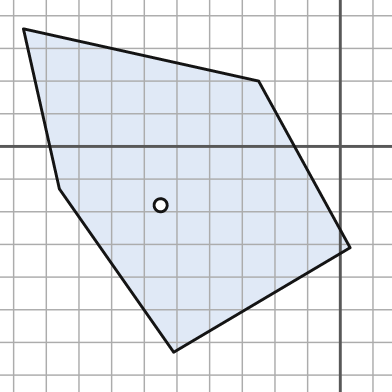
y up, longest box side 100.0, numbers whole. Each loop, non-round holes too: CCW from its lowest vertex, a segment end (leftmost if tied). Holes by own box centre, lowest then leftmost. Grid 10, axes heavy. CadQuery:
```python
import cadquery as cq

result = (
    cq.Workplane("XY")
    .moveTo(-51.0, -63.0)
    .lineTo(3.0, -31.0)
    .lineTo(-25.0, 20.0)
    .lineTo(-97.0, 36.0)
    .lineTo(-86.0, -13.0)
    .close()
    .moveTo(-55.0, -18.0)
    .circle(2.0)
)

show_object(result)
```